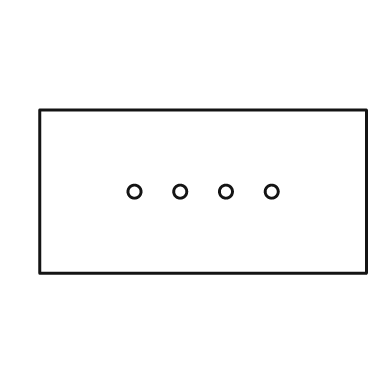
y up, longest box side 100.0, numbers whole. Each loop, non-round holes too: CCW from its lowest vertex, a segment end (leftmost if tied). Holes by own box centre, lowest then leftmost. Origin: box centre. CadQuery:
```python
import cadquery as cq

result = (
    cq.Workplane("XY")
    .moveTo(-50.0, -25.0)
    .lineTo(50.0, -25.0)
    .lineTo(50.0, 25.0)
    .lineTo(-50.0, 25.0)
    .close()
    .moveTo(-21.0, 0.0)
    .circle(2.0)
    .moveTo(-7.0, 0.0)
    .circle(2.0)
    .moveTo(7.0, 0.0)
    .circle(2.0)
    .moveTo(21.0, 0.0)
    .circle(2.0)
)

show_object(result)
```